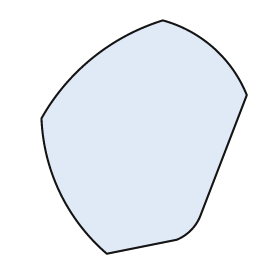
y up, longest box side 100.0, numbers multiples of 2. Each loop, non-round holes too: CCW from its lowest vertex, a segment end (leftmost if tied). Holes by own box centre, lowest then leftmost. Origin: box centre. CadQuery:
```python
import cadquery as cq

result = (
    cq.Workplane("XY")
    .moveTo(-16.0, -50.0)
    .lineTo(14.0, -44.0)
    .threePointArc((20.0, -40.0), (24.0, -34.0))
    .lineTo(44.0, 18.0)
    .threePointArc((30.0, 38.0), (8.0, 50.0))
    .threePointArc((-22.0, 34.0), (-44.0, 8.0))
    .threePointArc((-36.0, -24.0), (-16.0, -50.0))
    .close()
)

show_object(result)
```